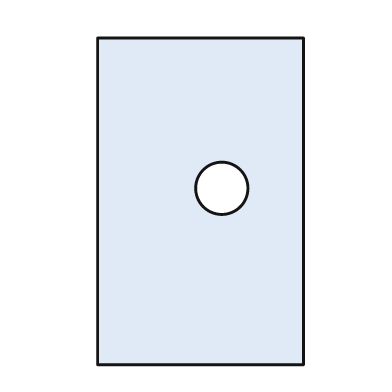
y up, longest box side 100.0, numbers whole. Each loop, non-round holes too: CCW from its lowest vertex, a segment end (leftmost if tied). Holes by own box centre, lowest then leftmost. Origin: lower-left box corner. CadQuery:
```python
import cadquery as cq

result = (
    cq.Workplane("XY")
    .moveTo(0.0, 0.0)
    .lineTo(63.0, 0.0)
    .lineTo(63.0, 100.0)
    .lineTo(0.0, 100.0)
    .close()
    .moveTo(38.0, 54.0)
    .circle(8.0)
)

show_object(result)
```